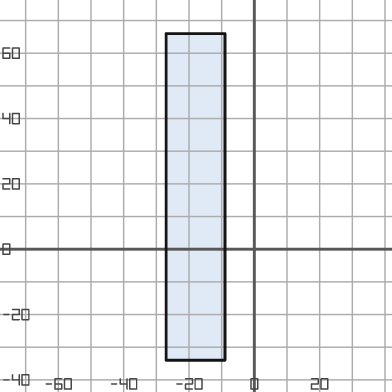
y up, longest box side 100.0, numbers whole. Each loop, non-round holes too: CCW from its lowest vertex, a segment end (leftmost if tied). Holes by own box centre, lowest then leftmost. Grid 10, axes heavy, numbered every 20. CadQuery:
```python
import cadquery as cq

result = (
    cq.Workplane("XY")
    .moveTo(-27.0, -34.0)
    .lineTo(-9.0, -34.0)
    .lineTo(-9.0, 66.0)
    .lineTo(-27.0, 66.0)
    .close()
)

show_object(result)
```